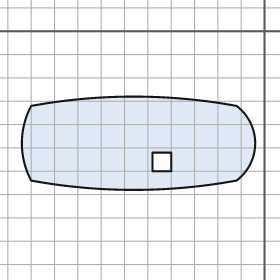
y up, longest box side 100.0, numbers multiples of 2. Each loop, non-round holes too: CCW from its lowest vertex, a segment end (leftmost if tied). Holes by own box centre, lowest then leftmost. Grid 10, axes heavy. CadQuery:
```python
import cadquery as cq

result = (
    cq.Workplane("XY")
    .moveTo(-100.0, -64.0)
    .threePointArc((-56.0, -68.0), (-12.0, -64.0))
    .threePointArc((-4.0, -48.0), (-12.0, -32.0))
    .threePointArc((-56.0, -28.0), (-100.0, -32.0))
    .threePointArc((-104.0, -48.0), (-100.0, -64.0))
    .close()
    .moveTo(-48.0, -60.0)
    .lineTo(-40.0, -60.0)
    .lineTo(-40.0, -52.0)
    .lineTo(-48.0, -52.0)
    .close()
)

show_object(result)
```